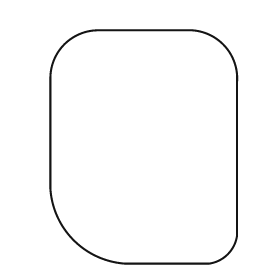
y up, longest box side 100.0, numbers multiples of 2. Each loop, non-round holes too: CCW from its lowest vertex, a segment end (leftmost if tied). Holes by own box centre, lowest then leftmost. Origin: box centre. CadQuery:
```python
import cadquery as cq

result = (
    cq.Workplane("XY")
    .moveTo(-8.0, -50.0)
    .lineTo(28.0, -50.0)
    .threePointArc((36.0, -46.0), (40.0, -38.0))
    .lineTo(40.0, 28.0)
    .threePointArc((34.0, 44.0), (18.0, 50.0))
    .lineTo(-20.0, 50.0)
    .threePointArc((-34.0, 44.0), (-40.0, 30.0))
    .lineTo(-40.0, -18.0)
    .threePointArc((-30.0, -40.0), (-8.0, -50.0))
    .close()
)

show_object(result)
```